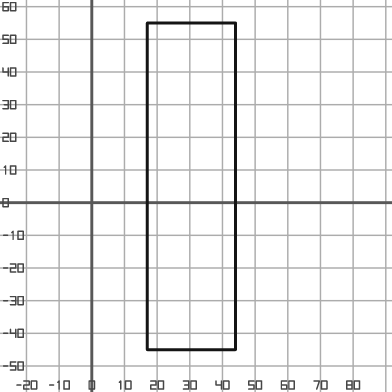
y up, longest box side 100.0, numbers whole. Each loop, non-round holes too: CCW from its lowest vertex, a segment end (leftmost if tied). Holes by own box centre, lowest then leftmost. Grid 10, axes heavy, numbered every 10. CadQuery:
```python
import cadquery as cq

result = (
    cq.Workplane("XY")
    .moveTo(17.0, -45.0)
    .lineTo(44.0, -45.0)
    .lineTo(44.0, 55.0)
    .lineTo(17.0, 55.0)
    .close()
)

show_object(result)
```